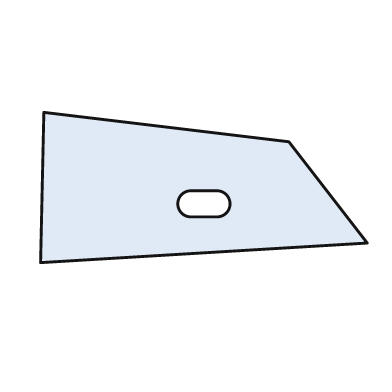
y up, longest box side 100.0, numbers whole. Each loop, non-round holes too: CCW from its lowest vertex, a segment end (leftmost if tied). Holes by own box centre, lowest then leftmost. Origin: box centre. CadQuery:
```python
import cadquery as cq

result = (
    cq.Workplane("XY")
    .moveTo(-50.0, -23.0)
    .lineTo(50.0, -17.0)
    .lineTo(26.0, 14.0)
    .lineTo(-49.0, 23.0)
    .close()
    .moveTo(-4.0, -9.0)
    .lineTo(4.0, -9.0)
    .threePointArc((8.0, -5.0), (4.0, -1.0))
    .lineTo(-4.0, -1.0)
    .threePointArc((-8.0, -5.0), (-4.0, -9.0))
    .close()
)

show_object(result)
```